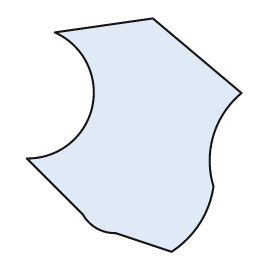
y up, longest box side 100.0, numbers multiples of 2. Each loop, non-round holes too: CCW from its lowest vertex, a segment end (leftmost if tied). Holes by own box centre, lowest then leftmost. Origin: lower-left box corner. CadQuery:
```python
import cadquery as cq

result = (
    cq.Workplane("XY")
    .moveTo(62.0, 0.0)
    .threePointArc((74.0, 12.0), (80.0, 28.0))
    .threePointArc((80.0, 50.0), (92.0, 68.0))
    .lineTo(54.0, 100.0)
    .lineTo(12.0, 94.0)
    .threePointArc((28.0, 62.0), (0.0, 40.0))
    .lineTo(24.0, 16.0)
    .threePointArc((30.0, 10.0), (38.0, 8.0))
    .close()
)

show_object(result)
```